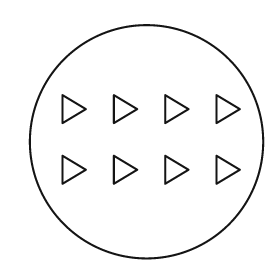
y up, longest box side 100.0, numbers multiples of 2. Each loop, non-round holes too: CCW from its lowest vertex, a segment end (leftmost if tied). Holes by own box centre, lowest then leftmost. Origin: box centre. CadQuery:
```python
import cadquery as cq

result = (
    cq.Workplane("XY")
    .moveTo(0.0, 0.0)
    .circle(50.0)
    .moveTo(-36.0, -18.0)
    .lineTo(-26.0, -12.0)
    .lineTo(-36.0, -6.0)
    .close()
    .moveTo(-14.0, -18.0)
    .lineTo(-4.0, -12.0)
    .lineTo(-14.0, -6.0)
    .close()
    .moveTo(8.0, -18.0)
    .lineTo(18.0, -12.0)
    .lineTo(8.0, -6.0)
    .close()
    .moveTo(30.0, -18.0)
    .lineTo(40.0, -12.0)
    .lineTo(30.0, -6.0)
    .close()
    .moveTo(-36.0, 8.0)
    .lineTo(-26.0, 14.0)
    .lineTo(-36.0, 20.0)
    .close()
    .moveTo(-14.0, 8.0)
    .lineTo(-4.0, 14.0)
    .lineTo(-14.0, 20.0)
    .close()
    .moveTo(8.0, 8.0)
    .lineTo(18.0, 14.0)
    .lineTo(8.0, 20.0)
    .close()
    .moveTo(30.0, 8.0)
    .lineTo(40.0, 14.0)
    .lineTo(30.0, 20.0)
    .close()
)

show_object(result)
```